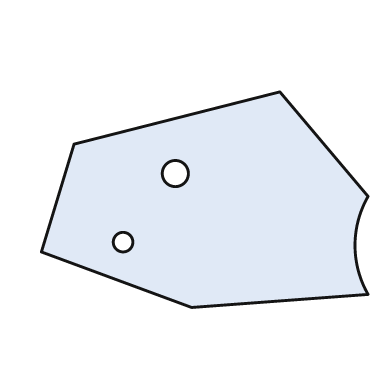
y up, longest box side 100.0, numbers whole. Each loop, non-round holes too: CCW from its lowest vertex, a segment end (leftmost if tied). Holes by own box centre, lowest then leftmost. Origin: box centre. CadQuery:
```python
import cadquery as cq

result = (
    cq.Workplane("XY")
    .moveTo(-4.0, -33.0)
    .lineTo(50.0, -29.0)
    .threePointArc((46.0, -14.0), (50.0, 1.0))
    .lineTo(23.0, 33.0)
    .lineTo(-40.0, 17.0)
    .lineTo(-50.0, -16.0)
    .close()
    .moveTo(-25.0, -13.0)
    .circle(3.0)
    .moveTo(-9.0, 8.0)
    .circle(4.0)
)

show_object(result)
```